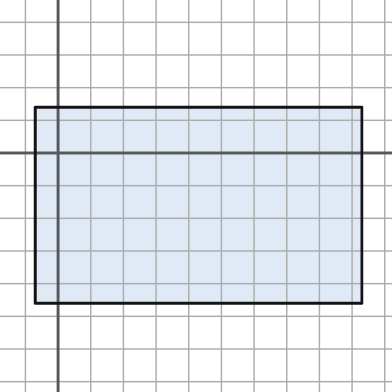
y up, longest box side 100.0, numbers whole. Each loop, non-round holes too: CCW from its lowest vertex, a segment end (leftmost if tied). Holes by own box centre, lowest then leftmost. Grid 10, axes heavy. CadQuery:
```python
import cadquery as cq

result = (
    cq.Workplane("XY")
    .moveTo(-7.0, -46.0)
    .lineTo(93.0, -46.0)
    .lineTo(93.0, 14.0)
    .lineTo(-7.0, 14.0)
    .close()
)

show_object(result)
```